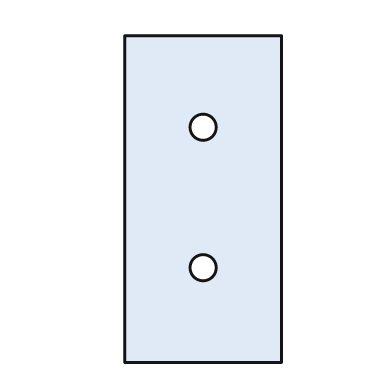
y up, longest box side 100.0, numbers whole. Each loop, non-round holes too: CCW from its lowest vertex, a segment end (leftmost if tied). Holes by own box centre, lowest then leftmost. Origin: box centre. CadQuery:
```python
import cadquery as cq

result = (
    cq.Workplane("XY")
    .moveTo(-24.0, -50.0)
    .lineTo(24.0, -50.0)
    .lineTo(24.0, 50.0)
    .lineTo(-24.0, 50.0)
    .close()
    .moveTo(0.0, -21.0)
    .circle(4.0)
    .moveTo(0.0, 22.0)
    .circle(4.0)
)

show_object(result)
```